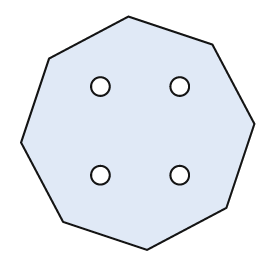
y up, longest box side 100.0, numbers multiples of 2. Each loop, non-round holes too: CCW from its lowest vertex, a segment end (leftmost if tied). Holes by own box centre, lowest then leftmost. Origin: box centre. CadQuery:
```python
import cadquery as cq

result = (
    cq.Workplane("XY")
    .moveTo(4.0, -50.0)
    .lineTo(38.0, -32.0)
    .lineTo(50.0, 4.0)
    .lineTo(32.0, 38.0)
    .lineTo(-4.0, 50.0)
    .lineTo(-38.0, 32.0)
    .lineTo(-50.0, -4.0)
    .lineTo(-32.0, -38.0)
    .close()
    .moveTo(-16.0, -18.0)
    .circle(4.0)
    .moveTo(18.0, -18.0)
    .circle(4.0)
    .moveTo(-16.0, 20.0)
    .circle(4.0)
    .moveTo(18.0, 20.0)
    .circle(4.0)
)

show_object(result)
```